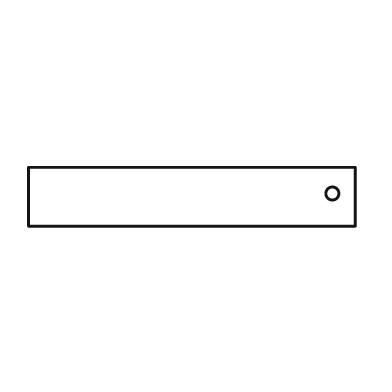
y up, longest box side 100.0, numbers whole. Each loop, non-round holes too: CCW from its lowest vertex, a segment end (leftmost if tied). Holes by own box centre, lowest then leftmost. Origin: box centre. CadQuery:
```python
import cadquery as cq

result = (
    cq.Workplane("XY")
    .moveTo(-50.0, -9.0)
    .lineTo(50.0, -9.0)
    .lineTo(50.0, 9.0)
    .lineTo(-50.0, 9.0)
    .close()
    .moveTo(43.0, 1.0)
    .circle(2.0)
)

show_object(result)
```